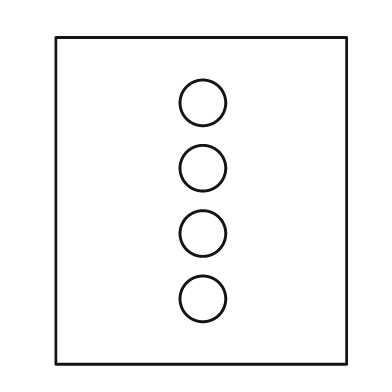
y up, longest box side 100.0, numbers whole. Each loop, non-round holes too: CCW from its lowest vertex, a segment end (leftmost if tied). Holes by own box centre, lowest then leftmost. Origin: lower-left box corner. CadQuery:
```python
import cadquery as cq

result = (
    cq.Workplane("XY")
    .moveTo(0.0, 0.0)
    .lineTo(89.0, 0.0)
    .lineTo(89.0, 100.0)
    .lineTo(0.0, 100.0)
    .close()
    .moveTo(45.0, 20.0)
    .circle(7.0)
    .moveTo(45.0, 40.0)
    .circle(7.0)
    .moveTo(45.0, 60.0)
    .circle(7.0)
    .moveTo(45.0, 80.0)
    .circle(7.0)
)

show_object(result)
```